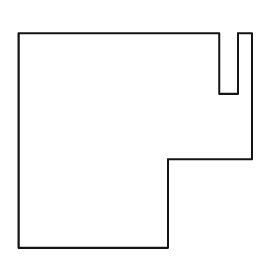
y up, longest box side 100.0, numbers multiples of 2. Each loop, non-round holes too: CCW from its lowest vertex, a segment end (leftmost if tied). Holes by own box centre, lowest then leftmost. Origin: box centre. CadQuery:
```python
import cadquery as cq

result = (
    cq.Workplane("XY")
    .moveTo(-50.0, -46.0)
    .lineTo(14.0, -46.0)
    .lineTo(14.0, -8.0)
    .lineTo(50.0, -8.0)
    .lineTo(50.0, 46.0)
    .lineTo(44.0, 46.0)
    .lineTo(44.0, 20.0)
    .lineTo(36.0, 20.0)
    .lineTo(36.0, 46.0)
    .lineTo(-50.0, 46.0)
    .close()
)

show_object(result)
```